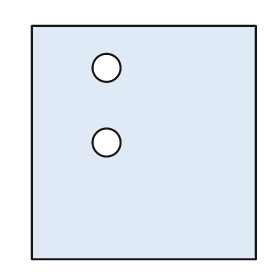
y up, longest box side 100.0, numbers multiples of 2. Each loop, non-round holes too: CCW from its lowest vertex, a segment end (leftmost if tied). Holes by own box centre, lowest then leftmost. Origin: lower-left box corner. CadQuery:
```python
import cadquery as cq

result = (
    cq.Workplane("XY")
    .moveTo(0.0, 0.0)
    .lineTo(96.0, 0.0)
    .lineTo(96.0, 100.0)
    .lineTo(0.0, 100.0)
    .close()
    .moveTo(32.0, 50.0)
    .circle(6.0)
    .moveTo(32.0, 82.0)
    .circle(6.0)
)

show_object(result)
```